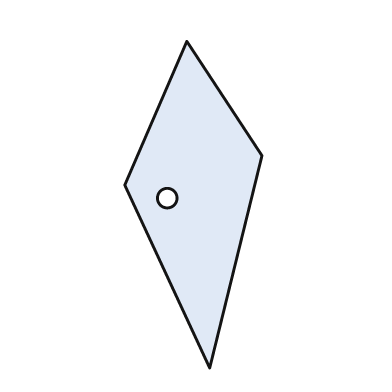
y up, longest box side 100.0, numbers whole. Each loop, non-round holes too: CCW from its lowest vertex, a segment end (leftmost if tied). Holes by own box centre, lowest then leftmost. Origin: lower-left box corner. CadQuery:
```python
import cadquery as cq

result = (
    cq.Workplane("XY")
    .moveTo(26.0, 0.0)
    .lineTo(42.0, 65.0)
    .lineTo(19.0, 100.0)
    .lineTo(0.0, 56.0)
    .close()
    .moveTo(13.0, 52.0)
    .circle(3.0)
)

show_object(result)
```